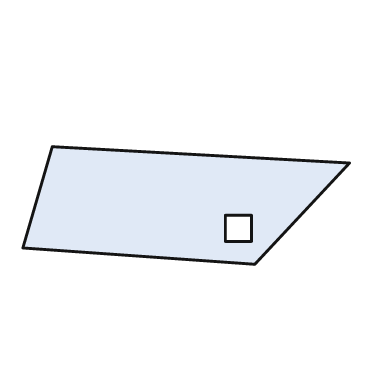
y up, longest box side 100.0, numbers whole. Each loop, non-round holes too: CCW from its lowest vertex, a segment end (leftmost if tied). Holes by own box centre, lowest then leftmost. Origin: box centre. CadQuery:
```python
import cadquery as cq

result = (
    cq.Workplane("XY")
    .moveTo(21.0, -18.0)
    .lineTo(50.0, 13.0)
    .lineTo(-41.0, 18.0)
    .lineTo(-50.0, -13.0)
    .close()
    .moveTo(12.0, -11.0)
    .lineTo(20.0, -11.0)
    .lineTo(20.0, -3.0)
    .lineTo(12.0, -3.0)
    .close()
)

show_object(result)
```